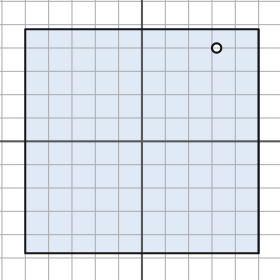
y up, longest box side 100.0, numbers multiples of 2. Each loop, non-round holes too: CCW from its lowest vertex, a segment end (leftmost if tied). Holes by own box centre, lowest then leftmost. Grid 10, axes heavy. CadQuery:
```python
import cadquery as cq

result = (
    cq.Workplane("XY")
    .moveTo(-50.0, -48.0)
    .lineTo(50.0, -48.0)
    .lineTo(50.0, 48.0)
    .lineTo(-50.0, 48.0)
    .close()
    .moveTo(32.0, 40.0)
    .circle(2.0)
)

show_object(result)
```